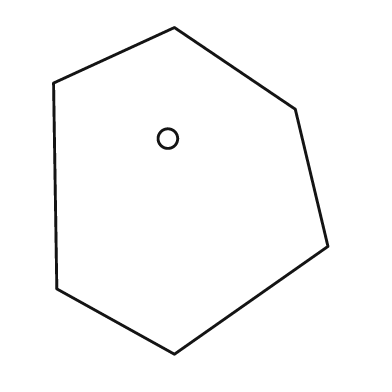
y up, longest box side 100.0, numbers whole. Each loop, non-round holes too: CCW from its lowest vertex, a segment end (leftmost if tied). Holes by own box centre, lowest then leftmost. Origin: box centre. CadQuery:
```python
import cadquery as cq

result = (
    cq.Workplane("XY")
    .moveTo(-5.0, -50.0)
    .lineTo(42.0, -17.0)
    .lineTo(32.0, 25.0)
    .lineTo(-5.0, 50.0)
    .lineTo(-42.0, 33.0)
    .lineTo(-41.0, -30.0)
    .close()
    .moveTo(-7.0, 16.0)
    .circle(3.0)
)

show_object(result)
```